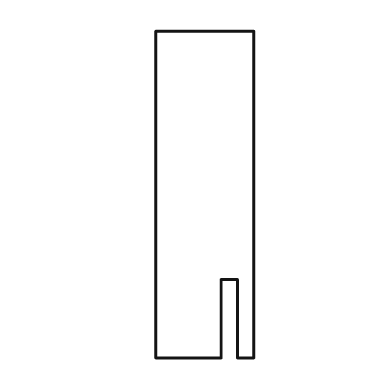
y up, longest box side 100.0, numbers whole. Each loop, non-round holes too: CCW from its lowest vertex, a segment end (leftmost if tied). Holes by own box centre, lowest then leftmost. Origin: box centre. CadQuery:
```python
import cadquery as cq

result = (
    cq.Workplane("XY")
    .moveTo(-15.0, -50.0)
    .lineTo(5.0, -50.0)
    .lineTo(5.0, -26.0)
    .lineTo(10.0, -26.0)
    .lineTo(10.0, -50.0)
    .lineTo(15.0, -50.0)
    .lineTo(15.0, 50.0)
    .lineTo(-15.0, 50.0)
    .close()
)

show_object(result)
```